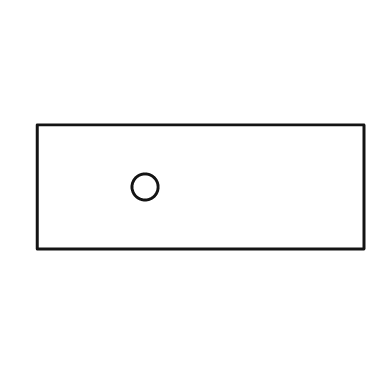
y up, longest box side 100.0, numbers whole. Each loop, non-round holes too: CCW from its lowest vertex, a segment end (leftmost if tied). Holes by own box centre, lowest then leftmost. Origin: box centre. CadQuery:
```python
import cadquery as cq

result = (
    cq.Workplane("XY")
    .moveTo(-50.0, -19.0)
    .lineTo(50.0, -19.0)
    .lineTo(50.0, 19.0)
    .lineTo(-50.0, 19.0)
    .close()
    .moveTo(-17.0, 0.0)
    .circle(4.0)
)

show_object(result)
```